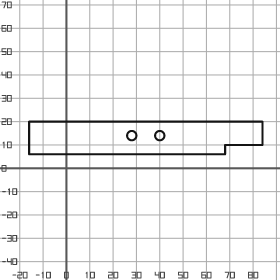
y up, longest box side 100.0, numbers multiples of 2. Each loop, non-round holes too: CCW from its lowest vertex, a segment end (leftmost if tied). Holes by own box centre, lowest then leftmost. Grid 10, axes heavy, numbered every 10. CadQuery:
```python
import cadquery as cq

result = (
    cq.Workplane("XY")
    .moveTo(-16.0, 6.0)
    .lineTo(68.0, 6.0)
    .lineTo(68.0, 10.0)
    .lineTo(84.0, 10.0)
    .lineTo(84.0, 20.0)
    .lineTo(-16.0, 20.0)
    .close()
    .moveTo(28.0, 14.0)
    .circle(2.0)
    .moveTo(40.0, 14.0)
    .circle(2.0)
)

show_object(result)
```